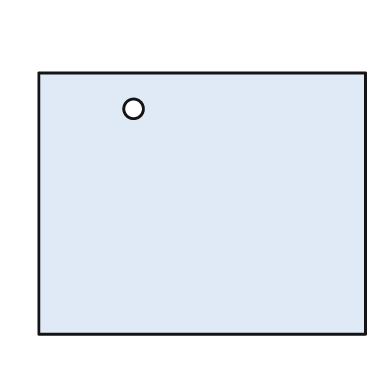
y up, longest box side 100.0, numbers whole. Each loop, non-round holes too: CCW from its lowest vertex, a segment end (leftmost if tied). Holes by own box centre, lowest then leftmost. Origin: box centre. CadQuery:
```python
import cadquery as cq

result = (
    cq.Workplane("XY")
    .moveTo(-50.0, -40.0)
    .lineTo(50.0, -40.0)
    .lineTo(50.0, 40.0)
    .lineTo(-50.0, 40.0)
    .close()
    .moveTo(-21.0, 29.0)
    .circle(3.0)
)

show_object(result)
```